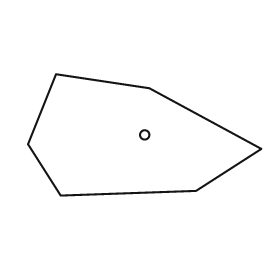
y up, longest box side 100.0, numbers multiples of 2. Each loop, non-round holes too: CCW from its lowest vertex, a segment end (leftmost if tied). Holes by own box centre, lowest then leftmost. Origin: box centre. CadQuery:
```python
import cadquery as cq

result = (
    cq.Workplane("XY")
    .moveTo(-36.0, -26.0)
    .lineTo(22.0, -24.0)
    .lineTo(50.0, -6.0)
    .lineTo(2.0, 20.0)
    .lineTo(-38.0, 26.0)
    .lineTo(-50.0, -4.0)
    .close()
    .moveTo(0.0, 0.0)
    .circle(2.0)
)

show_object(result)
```